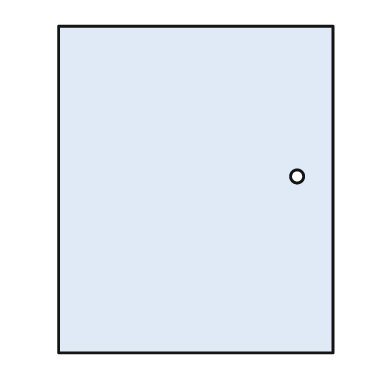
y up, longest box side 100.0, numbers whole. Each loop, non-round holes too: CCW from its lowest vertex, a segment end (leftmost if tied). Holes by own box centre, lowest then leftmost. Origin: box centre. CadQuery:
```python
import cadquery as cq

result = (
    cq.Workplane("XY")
    .moveTo(-42.0, -50.0)
    .lineTo(42.0, -50.0)
    .lineTo(42.0, 50.0)
    .lineTo(-42.0, 50.0)
    .close()
    .moveTo(31.0, 4.0)
    .circle(2.0)
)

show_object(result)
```